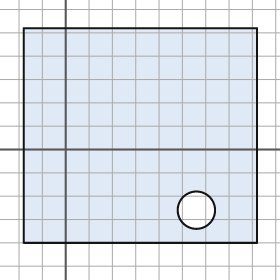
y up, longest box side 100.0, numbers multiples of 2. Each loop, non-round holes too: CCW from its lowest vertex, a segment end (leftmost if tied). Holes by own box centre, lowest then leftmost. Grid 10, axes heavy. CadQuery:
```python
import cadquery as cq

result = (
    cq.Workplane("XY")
    .moveTo(-18.0, -40.0)
    .lineTo(82.0, -40.0)
    .lineTo(82.0, 52.0)
    .lineTo(-18.0, 52.0)
    .close()
    .moveTo(56.0, -26.0)
    .circle(8.0)
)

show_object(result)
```